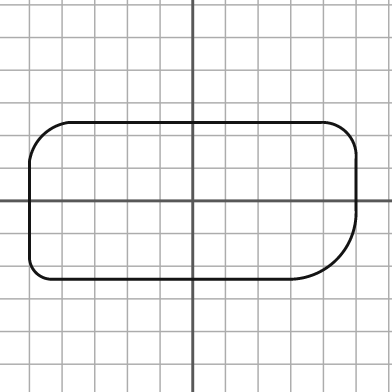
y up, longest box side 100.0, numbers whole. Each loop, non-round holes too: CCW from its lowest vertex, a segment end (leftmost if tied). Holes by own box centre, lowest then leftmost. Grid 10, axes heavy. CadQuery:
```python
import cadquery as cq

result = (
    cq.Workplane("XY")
    .moveTo(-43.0, -24.0)
    .lineTo(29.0, -24.0)
    .threePointArc((44.0, -18.0), (50.0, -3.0))
    .lineTo(50.0, 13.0)
    .threePointArc((47.0, 21.0), (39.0, 24.0))
    .lineTo(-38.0, 24.0)
    .threePointArc((-46.0, 20.0), (-50.0, 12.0))
    .lineTo(-50.0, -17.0)
    .threePointArc((-48.0, -22.0), (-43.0, -24.0))
    .close()
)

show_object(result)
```